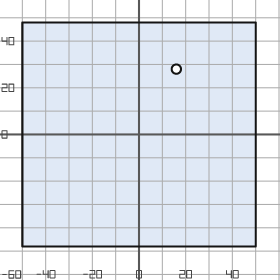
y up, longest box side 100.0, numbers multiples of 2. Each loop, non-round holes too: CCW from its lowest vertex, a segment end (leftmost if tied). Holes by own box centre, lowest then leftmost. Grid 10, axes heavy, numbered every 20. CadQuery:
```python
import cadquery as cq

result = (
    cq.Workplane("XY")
    .moveTo(-50.0, -48.0)
    .lineTo(50.0, -48.0)
    .lineTo(50.0, 48.0)
    .lineTo(-50.0, 48.0)
    .close()
    .moveTo(16.0, 28.0)
    .circle(2.0)
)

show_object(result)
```